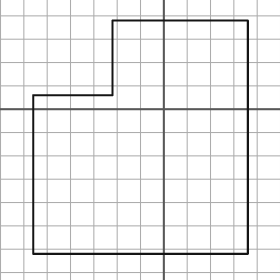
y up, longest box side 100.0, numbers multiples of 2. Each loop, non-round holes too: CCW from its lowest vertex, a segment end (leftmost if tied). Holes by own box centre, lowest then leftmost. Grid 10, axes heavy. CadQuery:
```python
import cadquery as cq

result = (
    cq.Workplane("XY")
    .moveTo(-56.0, -62.0)
    .lineTo(36.0, -62.0)
    .lineTo(36.0, 38.0)
    .lineTo(-22.0, 38.0)
    .lineTo(-22.0, 6.0)
    .lineTo(-56.0, 6.0)
    .close()
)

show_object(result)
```